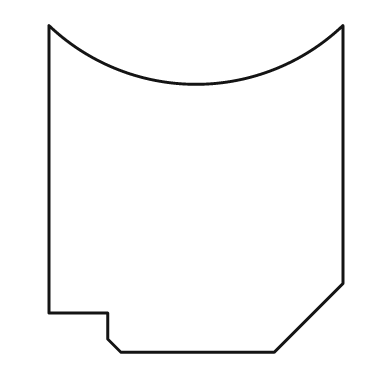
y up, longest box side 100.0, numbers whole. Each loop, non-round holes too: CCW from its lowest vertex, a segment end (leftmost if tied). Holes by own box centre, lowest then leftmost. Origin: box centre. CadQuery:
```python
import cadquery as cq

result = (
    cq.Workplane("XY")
    .moveTo(-23.0, -50.0)
    .lineTo(24.0, -50.0)
    .lineTo(45.0, -29.0)
    .lineTo(45.0, 50.0)
    .threePointArc((0.0, 32.0), (-45.0, 50.0))
    .lineTo(-45.0, -38.0)
    .lineTo(-27.0, -38.0)
    .lineTo(-27.0, -46.0)
    .close()
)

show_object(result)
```